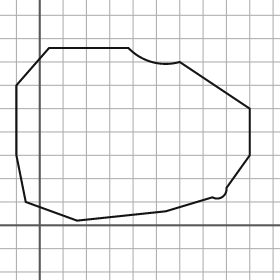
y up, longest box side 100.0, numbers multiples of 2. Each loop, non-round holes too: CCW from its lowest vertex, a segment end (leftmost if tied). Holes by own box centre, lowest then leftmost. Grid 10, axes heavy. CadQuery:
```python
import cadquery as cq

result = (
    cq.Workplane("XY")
    .moveTo(16.0, 2.0)
    .lineTo(54.0, 6.0)
    .lineTo(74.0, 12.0)
    .threePointArc((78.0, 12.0), (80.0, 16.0))
    .lineTo(90.0, 30.0)
    .lineTo(90.0, 50.0)
    .lineTo(60.0, 70.0)
    .threePointArc((48.0, 70.0), (38.0, 76.0))
    .lineTo(4.0, 76.0)
    .lineTo(-10.0, 60.0)
    .lineTo(-10.0, 30.0)
    .lineTo(-6.0, 10.0)
    .close()
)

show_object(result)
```